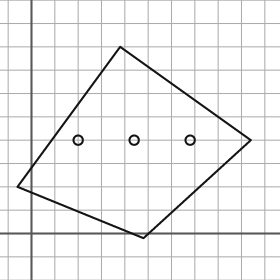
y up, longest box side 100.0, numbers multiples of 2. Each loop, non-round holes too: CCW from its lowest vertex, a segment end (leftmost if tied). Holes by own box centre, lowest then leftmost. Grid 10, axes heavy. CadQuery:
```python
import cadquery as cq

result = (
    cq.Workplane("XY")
    .moveTo(48.0, -2.0)
    .lineTo(94.0, 40.0)
    .lineTo(38.0, 80.0)
    .lineTo(-6.0, 20.0)
    .close()
    .moveTo(20.0, 40.0)
    .circle(2.0)
    .moveTo(44.0, 40.0)
    .circle(2.0)
    .moveTo(68.0, 40.0)
    .circle(2.0)
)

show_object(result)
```